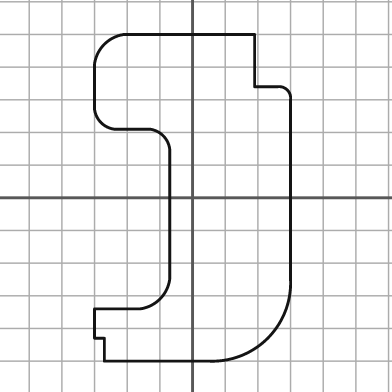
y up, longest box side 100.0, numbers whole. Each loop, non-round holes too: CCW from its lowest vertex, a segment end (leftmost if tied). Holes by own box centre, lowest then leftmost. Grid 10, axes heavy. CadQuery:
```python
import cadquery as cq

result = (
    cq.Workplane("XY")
    .moveTo(-27.0, -50.0)
    .lineTo(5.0, -50.0)
    .threePointArc((23.0, -43.0), (30.0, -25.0))
    .lineTo(30.0, 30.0)
    .threePointArc((29.0, 33.0), (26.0, 34.0))
    .lineTo(19.0, 34.0)
    .lineTo(19.0, 50.0)
    .lineTo(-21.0, 50.0)
    .threePointArc((-27.0, 47.0), (-30.0, 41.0))
    .lineTo(-30.0, 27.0)
    .threePointArc((-28.0, 23.0), (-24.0, 21.0))
    .lineTo(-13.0, 21.0)
    .threePointArc((-9.0, 19.0), (-7.0, 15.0))
    .lineTo(-7.0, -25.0)
    .threePointArc((-10.0, -31.0), (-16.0, -34.0))
    .lineTo(-30.0, -34.0)
    .lineTo(-30.0, -43.0)
    .lineTo(-27.0, -43.0)
    .close()
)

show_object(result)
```